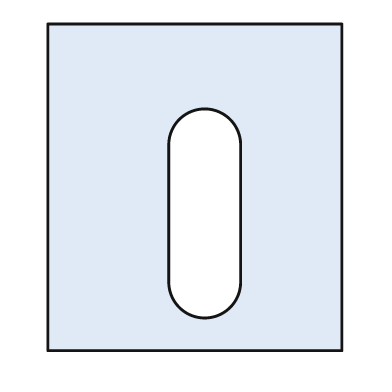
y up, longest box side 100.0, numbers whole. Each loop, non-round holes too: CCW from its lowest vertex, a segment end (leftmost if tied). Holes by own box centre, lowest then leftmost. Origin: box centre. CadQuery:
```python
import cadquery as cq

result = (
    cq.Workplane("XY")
    .moveTo(-45.0, -50.0)
    .lineTo(45.0, -50.0)
    .lineTo(45.0, 50.0)
    .lineTo(-45.0, 50.0)
    .close()
    .moveTo(-8.0, -29.0)
    .threePointArc((3.0, -40.0), (14.0, -29.0))
    .lineTo(14.0, 13.0)
    .threePointArc((3.0, 24.0), (-8.0, 13.0))
    .close()
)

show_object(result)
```